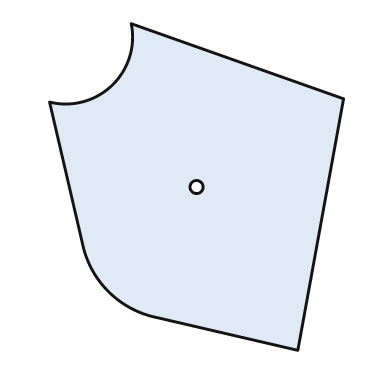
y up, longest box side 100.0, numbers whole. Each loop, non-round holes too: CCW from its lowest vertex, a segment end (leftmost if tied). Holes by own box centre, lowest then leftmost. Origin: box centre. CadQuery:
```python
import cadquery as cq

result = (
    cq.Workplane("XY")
    .moveTo(31.0, -50.0)
    .lineTo(45.0, 27.0)
    .lineTo(-20.0, 50.0)
    .threePointArc((-26.0, 31.0), (-45.0, 26.0))
    .lineTo(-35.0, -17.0)
    .threePointArc((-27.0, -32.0), (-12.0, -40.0))
    .close()
    .moveTo(0.0, 0.0)
    .circle(2.0)
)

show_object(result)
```